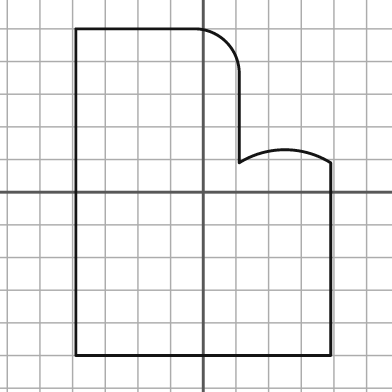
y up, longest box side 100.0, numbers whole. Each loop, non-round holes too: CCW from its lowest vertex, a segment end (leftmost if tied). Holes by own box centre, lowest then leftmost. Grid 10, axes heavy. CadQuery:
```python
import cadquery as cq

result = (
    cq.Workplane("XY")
    .moveTo(-39.0, -50.0)
    .lineTo(39.0, -50.0)
    .lineTo(39.0, 9.0)
    .threePointArc((25.0, 13.0), (11.0, 9.0))
    .lineTo(11.0, 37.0)
    .threePointArc((7.0, 46.0), (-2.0, 50.0))
    .lineTo(-39.0, 50.0)
    .close()
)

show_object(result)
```